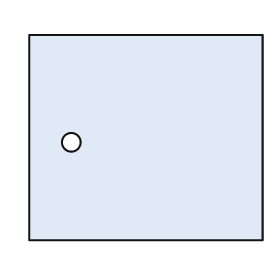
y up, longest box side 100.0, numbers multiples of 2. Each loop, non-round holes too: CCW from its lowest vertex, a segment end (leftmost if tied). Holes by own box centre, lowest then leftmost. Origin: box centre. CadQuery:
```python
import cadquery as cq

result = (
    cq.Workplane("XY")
    .moveTo(-50.0, -44.0)
    .lineTo(50.0, -44.0)
    .lineTo(50.0, 44.0)
    .lineTo(-50.0, 44.0)
    .close()
    .moveTo(-32.0, -2.0)
    .circle(4.0)
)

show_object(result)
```